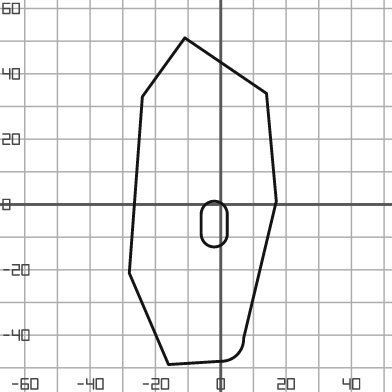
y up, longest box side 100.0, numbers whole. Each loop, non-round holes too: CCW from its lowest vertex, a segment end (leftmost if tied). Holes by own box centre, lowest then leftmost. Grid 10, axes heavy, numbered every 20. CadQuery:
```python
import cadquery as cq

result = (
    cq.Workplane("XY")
    .moveTo(-16.0, -49.0)
    .lineTo(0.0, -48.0)
    .threePointArc((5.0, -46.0), (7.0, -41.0))
    .lineTo(17.0, 1.0)
    .lineTo(14.0, 34.0)
    .lineTo(-11.0, 51.0)
    .lineTo(-24.0, 33.0)
    .lineTo(-28.0, -21.0)
    .close()
    .moveTo(-6.0, -9.0)
    .threePointArc((-2.0, -13.0), (2.0, -9.0))
    .lineTo(2.0, -3.0)
    .threePointArc((-2.0, 1.0), (-6.0, -3.0))
    .close()
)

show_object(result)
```